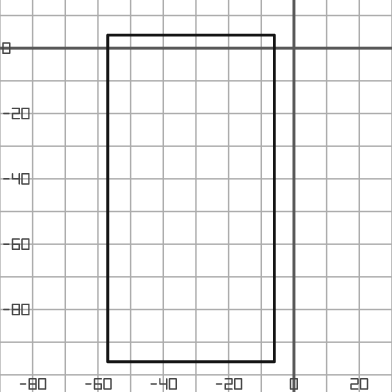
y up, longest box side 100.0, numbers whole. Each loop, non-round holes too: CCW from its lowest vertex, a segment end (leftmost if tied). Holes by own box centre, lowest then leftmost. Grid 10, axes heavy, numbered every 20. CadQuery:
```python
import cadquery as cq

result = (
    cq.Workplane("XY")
    .moveTo(-57.0, -96.0)
    .lineTo(-6.0, -96.0)
    .lineTo(-6.0, 4.0)
    .lineTo(-57.0, 4.0)
    .close()
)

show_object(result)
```